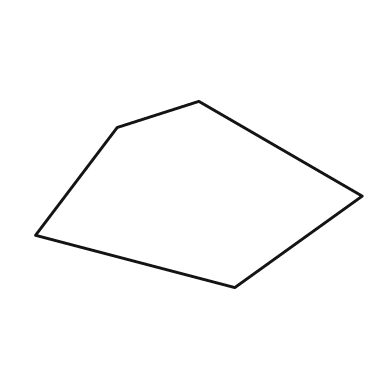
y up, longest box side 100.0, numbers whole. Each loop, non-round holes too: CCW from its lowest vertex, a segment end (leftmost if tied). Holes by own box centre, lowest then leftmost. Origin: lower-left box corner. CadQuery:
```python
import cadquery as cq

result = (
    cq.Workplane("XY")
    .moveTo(61.0, 0.0)
    .lineTo(100.0, 28.0)
    .lineTo(50.0, 57.0)
    .lineTo(25.0, 49.0)
    .lineTo(0.0, 16.0)
    .close()
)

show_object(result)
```